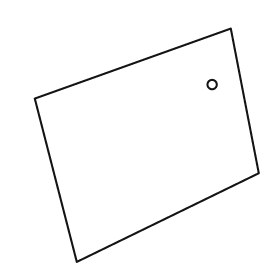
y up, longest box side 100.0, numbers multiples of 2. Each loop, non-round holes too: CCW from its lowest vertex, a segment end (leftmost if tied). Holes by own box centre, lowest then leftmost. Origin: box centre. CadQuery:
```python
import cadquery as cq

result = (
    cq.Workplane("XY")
    .moveTo(-30.0, -50.0)
    .lineTo(48.0, -12.0)
    .lineTo(36.0, 50.0)
    .lineTo(-48.0, 20.0)
    .close()
    .moveTo(28.0, 26.0)
    .circle(2.0)
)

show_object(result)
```